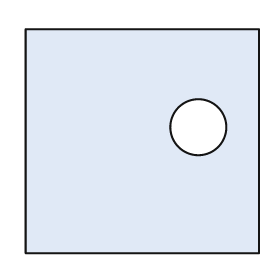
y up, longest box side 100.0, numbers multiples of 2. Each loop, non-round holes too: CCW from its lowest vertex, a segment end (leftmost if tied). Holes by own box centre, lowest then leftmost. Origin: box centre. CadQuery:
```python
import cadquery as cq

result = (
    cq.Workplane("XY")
    .moveTo(-50.0, -48.0)
    .lineTo(50.0, -48.0)
    .lineTo(50.0, 48.0)
    .lineTo(-50.0, 48.0)
    .close()
    .moveTo(24.0, 6.0)
    .circle(12.0)
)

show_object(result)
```